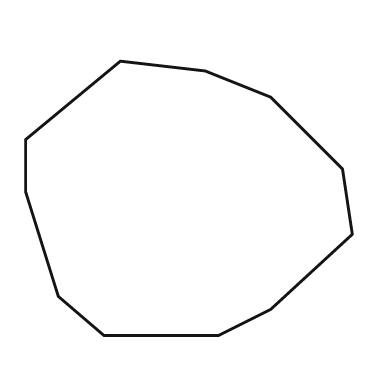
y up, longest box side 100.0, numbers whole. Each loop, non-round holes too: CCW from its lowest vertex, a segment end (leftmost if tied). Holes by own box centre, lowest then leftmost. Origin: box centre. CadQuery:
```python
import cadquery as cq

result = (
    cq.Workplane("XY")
    .moveTo(-26.0, -42.0)
    .lineTo(9.0, -42.0)
    .lineTo(25.0, -34.0)
    .lineTo(50.0, -11.0)
    .lineTo(47.0, 9.0)
    .lineTo(25.0, 31.0)
    .lineTo(5.0, 39.0)
    .lineTo(-21.0, 42.0)
    .lineTo(-50.0, 18.0)
    .lineTo(-50.0, 2.0)
    .lineTo(-40.0, -30.0)
    .close()
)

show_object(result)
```